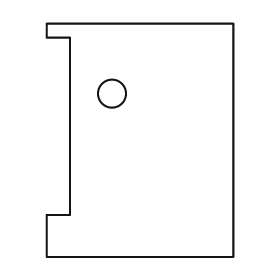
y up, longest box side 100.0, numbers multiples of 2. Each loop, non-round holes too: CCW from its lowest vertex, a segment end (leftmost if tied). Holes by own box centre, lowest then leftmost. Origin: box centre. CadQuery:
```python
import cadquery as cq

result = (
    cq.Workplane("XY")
    .moveTo(-40.0, -50.0)
    .lineTo(40.0, -50.0)
    .lineTo(40.0, 50.0)
    .lineTo(-40.0, 50.0)
    .lineTo(-40.0, 44.0)
    .lineTo(-30.0, 44.0)
    .lineTo(-30.0, -32.0)
    .lineTo(-40.0, -32.0)
    .close()
    .moveTo(-12.0, 20.0)
    .circle(6.0)
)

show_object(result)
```